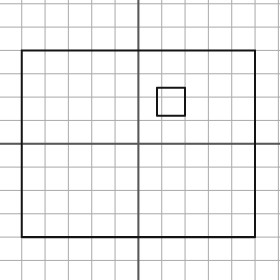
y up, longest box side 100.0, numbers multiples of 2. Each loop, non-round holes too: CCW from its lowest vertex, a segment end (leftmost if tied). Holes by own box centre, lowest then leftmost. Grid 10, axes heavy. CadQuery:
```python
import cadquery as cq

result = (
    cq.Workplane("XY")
    .moveTo(-50.0, -40.0)
    .lineTo(50.0, -40.0)
    .lineTo(50.0, 40.0)
    .lineTo(-50.0, 40.0)
    .close()
    .moveTo(8.0, 12.0)
    .lineTo(20.0, 12.0)
    .lineTo(20.0, 24.0)
    .lineTo(8.0, 24.0)
    .close()
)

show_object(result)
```